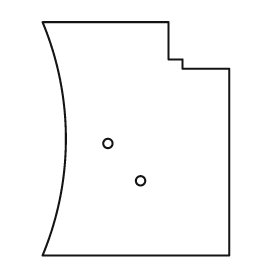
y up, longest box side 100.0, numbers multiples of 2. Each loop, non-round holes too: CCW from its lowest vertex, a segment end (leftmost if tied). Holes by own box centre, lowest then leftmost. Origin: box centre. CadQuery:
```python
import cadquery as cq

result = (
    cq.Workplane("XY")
    .moveTo(-40.0, -50.0)
    .lineTo(40.0, -50.0)
    .lineTo(40.0, 30.0)
    .lineTo(20.0, 30.0)
    .lineTo(20.0, 34.0)
    .lineTo(14.0, 34.0)
    .lineTo(14.0, 50.0)
    .lineTo(-40.0, 50.0)
    .threePointArc((-30.0, 0.0), (-40.0, -50.0))
    .close()
    .moveTo(2.0, -18.0)
    .circle(2.0)
    .moveTo(-12.0, -2.0)
    .circle(2.0)
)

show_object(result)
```